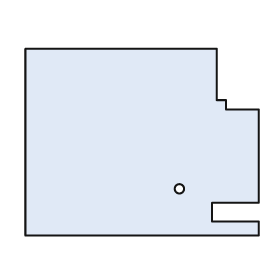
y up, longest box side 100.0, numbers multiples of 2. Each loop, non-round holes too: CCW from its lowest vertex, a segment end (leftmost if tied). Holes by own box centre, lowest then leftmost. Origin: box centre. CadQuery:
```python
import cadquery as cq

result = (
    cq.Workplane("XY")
    .moveTo(-50.0, -40.0)
    .lineTo(50.0, -40.0)
    .lineTo(50.0, -34.0)
    .lineTo(30.0, -34.0)
    .lineTo(30.0, -26.0)
    .lineTo(50.0, -26.0)
    .lineTo(50.0, 14.0)
    .lineTo(36.0, 14.0)
    .lineTo(36.0, 18.0)
    .lineTo(32.0, 18.0)
    .lineTo(32.0, 40.0)
    .lineTo(-50.0, 40.0)
    .close()
    .moveTo(16.0, -20.0)
    .circle(2.0)
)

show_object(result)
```